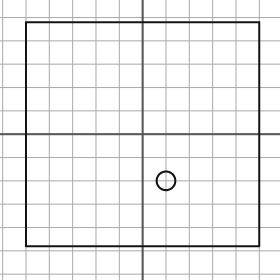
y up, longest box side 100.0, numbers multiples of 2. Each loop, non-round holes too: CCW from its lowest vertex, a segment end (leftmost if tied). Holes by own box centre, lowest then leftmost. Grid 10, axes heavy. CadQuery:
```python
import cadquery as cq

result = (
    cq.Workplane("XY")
    .moveTo(-50.0, -48.0)
    .lineTo(50.0, -48.0)
    .lineTo(50.0, 48.0)
    .lineTo(-50.0, 48.0)
    .close()
    .moveTo(10.0, -20.0)
    .circle(4.0)
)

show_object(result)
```